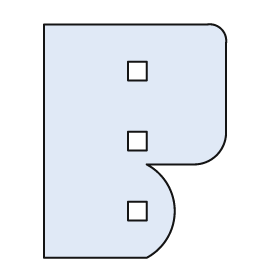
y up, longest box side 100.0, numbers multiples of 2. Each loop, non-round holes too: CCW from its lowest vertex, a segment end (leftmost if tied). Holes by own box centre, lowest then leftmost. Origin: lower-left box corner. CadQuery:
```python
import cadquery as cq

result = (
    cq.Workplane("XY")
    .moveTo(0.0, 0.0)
    .lineTo(44.0, 0.0)
    .threePointArc((56.0, 20.0), (44.0, 40.0))
    .lineTo(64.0, 40.0)
    .threePointArc((74.0, 44.0), (78.0, 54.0))
    .lineTo(78.0, 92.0)
    .threePointArc((76.0, 98.0), (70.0, 100.0))
    .lineTo(0.0, 100.0)
    .close()
    .moveTo(36.0, 16.0)
    .lineTo(44.0, 16.0)
    .lineTo(44.0, 24.0)
    .lineTo(36.0, 24.0)
    .close()
    .moveTo(36.0, 46.0)
    .lineTo(44.0, 46.0)
    .lineTo(44.0, 54.0)
    .lineTo(36.0, 54.0)
    .close()
    .moveTo(36.0, 76.0)
    .lineTo(44.0, 76.0)
    .lineTo(44.0, 84.0)
    .lineTo(36.0, 84.0)
    .close()
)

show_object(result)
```